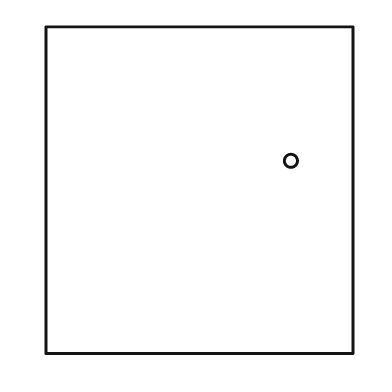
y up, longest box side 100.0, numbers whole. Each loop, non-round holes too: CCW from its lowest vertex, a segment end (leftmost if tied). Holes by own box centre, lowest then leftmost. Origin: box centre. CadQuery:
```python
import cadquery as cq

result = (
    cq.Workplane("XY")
    .moveTo(-47.0, -50.0)
    .lineTo(47.0, -50.0)
    .lineTo(47.0, 50.0)
    .lineTo(-47.0, 50.0)
    .close()
    .moveTo(28.0, 9.0)
    .circle(2.0)
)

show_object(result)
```